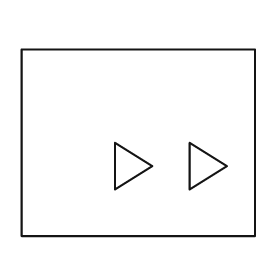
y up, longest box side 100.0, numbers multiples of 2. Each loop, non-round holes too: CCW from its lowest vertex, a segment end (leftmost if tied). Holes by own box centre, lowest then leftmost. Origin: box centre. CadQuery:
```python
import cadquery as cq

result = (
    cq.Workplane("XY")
    .moveTo(-50.0, -40.0)
    .lineTo(50.0, -40.0)
    .lineTo(50.0, 40.0)
    .lineTo(-50.0, 40.0)
    .close()
    .moveTo(-10.0, -20.0)
    .lineTo(6.0, -10.0)
    .lineTo(-10.0, 0.0)
    .close()
    .moveTo(22.0, -20.0)
    .lineTo(38.0, -10.0)
    .lineTo(22.0, 0.0)
    .close()
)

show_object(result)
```